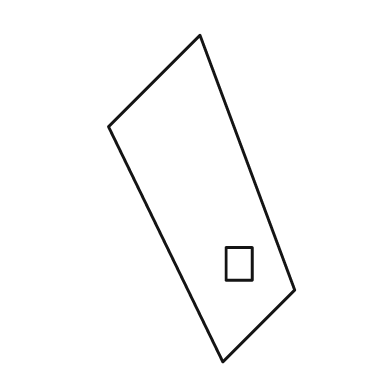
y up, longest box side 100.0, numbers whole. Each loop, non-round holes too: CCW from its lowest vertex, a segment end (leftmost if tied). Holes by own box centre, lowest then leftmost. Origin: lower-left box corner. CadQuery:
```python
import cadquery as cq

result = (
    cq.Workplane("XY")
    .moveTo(35.0, 0.0)
    .lineTo(57.0, 22.0)
    .lineTo(28.0, 100.0)
    .lineTo(0.0, 72.0)
    .close()
    .moveTo(36.0, 25.0)
    .lineTo(44.0, 25.0)
    .lineTo(44.0, 35.0)
    .lineTo(36.0, 35.0)
    .close()
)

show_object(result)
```